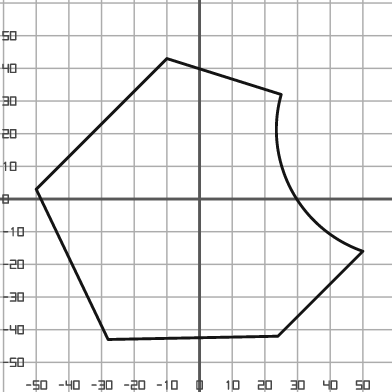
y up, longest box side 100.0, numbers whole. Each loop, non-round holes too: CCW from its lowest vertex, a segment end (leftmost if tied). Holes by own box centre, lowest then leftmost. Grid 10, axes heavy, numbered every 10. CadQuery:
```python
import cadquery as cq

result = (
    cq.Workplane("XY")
    .moveTo(-28.0, -43.0)
    .lineTo(24.0, -42.0)
    .lineTo(50.0, -16.0)
    .threePointArc((28.0, 3.0), (25.0, 32.0))
    .lineTo(-10.0, 43.0)
    .lineTo(-50.0, 3.0)
    .close()
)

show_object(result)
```